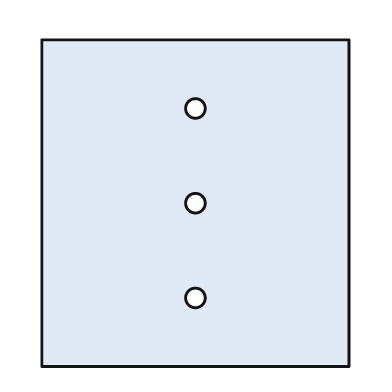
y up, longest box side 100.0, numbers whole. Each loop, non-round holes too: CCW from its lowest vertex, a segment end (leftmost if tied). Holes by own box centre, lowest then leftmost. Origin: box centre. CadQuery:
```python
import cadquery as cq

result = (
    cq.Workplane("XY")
    .moveTo(-47.0, -50.0)
    .lineTo(47.0, -50.0)
    .lineTo(47.0, 50.0)
    .lineTo(-47.0, 50.0)
    .close()
    .moveTo(0.0, -29.0)
    .circle(3.0)
    .moveTo(0.0, 0.0)
    .circle(3.0)
    .moveTo(0.0, 29.0)
    .circle(3.0)
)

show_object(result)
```